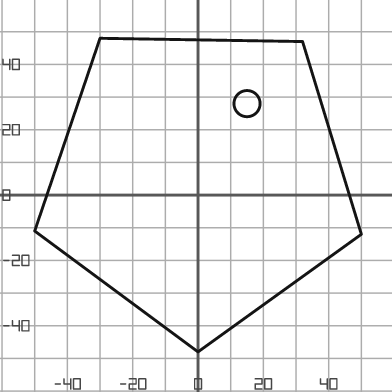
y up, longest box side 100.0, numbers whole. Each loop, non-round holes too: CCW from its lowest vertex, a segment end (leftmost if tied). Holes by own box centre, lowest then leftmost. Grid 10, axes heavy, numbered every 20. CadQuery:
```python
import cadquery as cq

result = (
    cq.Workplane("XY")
    .moveTo(0.0, -48.0)
    .lineTo(50.0, -12.0)
    .lineTo(32.0, 47.0)
    .lineTo(-30.0, 48.0)
    .lineTo(-50.0, -11.0)
    .close()
    .moveTo(15.0, 28.0)
    .circle(4.0)
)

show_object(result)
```